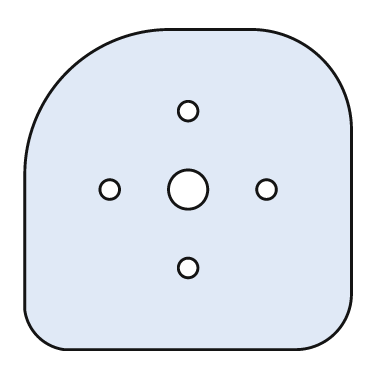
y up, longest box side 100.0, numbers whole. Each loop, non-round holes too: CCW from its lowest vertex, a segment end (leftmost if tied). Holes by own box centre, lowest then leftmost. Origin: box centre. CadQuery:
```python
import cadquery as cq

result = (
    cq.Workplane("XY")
    .moveTo(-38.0, -49.0)
    .lineTo(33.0, -49.0)
    .threePointArc((45.0, -44.0), (50.0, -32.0))
    .lineTo(50.0, 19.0)
    .threePointArc((41.0, 40.0), (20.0, 49.0))
    .lineTo(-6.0, 49.0)
    .threePointArc((-37.0, 36.0), (-50.0, 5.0))
    .lineTo(-50.0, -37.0)
    .threePointArc((-46.0, -45.0), (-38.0, -49.0))
    .close()
    .moveTo(0.0, -24.0)
    .circle(3.0)
    .moveTo(-24.0, 0.0)
    .circle(3.0)
    .moveTo(0.0, 0.0)
    .circle(6.0)
    .moveTo(24.0, 0.0)
    .circle(3.0)
    .moveTo(0.0, 24.0)
    .circle(3.0)
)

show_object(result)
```